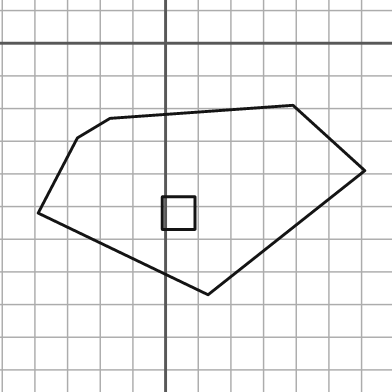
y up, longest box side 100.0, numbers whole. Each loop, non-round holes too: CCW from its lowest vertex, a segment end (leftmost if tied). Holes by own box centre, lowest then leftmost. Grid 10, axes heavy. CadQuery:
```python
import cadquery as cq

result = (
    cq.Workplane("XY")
    .moveTo(13.0, -77.0)
    .lineTo(61.0, -39.0)
    .lineTo(39.0, -19.0)
    .lineTo(-17.0, -23.0)
    .lineTo(-27.0, -29.0)
    .lineTo(-39.0, -52.0)
    .close()
    .moveTo(-1.0, -57.0)
    .lineTo(9.0, -57.0)
    .lineTo(9.0, -47.0)
    .lineTo(-1.0, -47.0)
    .close()
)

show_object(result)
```